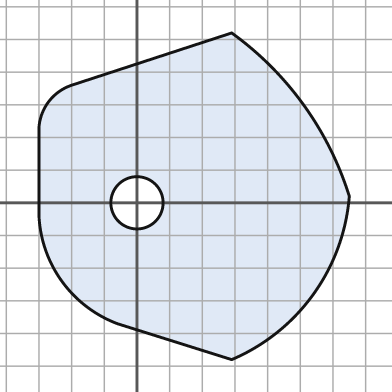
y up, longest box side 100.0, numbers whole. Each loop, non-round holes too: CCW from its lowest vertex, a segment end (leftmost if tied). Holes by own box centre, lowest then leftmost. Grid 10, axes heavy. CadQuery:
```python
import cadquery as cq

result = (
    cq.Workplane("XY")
    .moveTo(29.0, -48.0)
    .threePointArc((54.0, -28.0), (65.0, 2.0))
    .threePointArc((51.0, 30.0), (29.0, 52.0))
    .lineTo(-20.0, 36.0)
    .threePointArc((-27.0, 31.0), (-30.0, 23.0))
    .lineTo(-30.0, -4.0)
    .threePointArc((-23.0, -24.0), (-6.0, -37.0))
    .close()
    .moveTo(0.0, 0.0)
    .circle(8.0)
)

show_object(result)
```